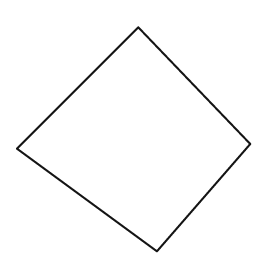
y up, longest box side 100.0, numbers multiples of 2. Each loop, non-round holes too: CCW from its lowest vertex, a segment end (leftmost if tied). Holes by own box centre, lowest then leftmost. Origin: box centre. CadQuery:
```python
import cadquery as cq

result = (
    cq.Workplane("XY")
    .moveTo(10.0, -48.0)
    .lineTo(50.0, -2.0)
    .lineTo(2.0, 48.0)
    .lineTo(-50.0, -4.0)
    .close()
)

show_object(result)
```